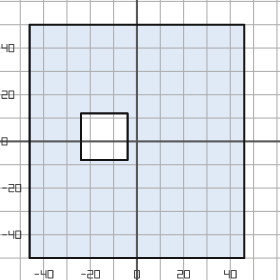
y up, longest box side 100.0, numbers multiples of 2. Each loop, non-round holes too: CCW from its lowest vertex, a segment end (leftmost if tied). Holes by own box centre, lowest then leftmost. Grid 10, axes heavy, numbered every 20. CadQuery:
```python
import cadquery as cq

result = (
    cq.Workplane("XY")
    .moveTo(-46.0, -50.0)
    .lineTo(46.0, -50.0)
    .lineTo(46.0, 50.0)
    .lineTo(-46.0, 50.0)
    .close()
    .moveTo(-24.0, -8.0)
    .lineTo(-4.0, -8.0)
    .lineTo(-4.0, 12.0)
    .lineTo(-24.0, 12.0)
    .close()
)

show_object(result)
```